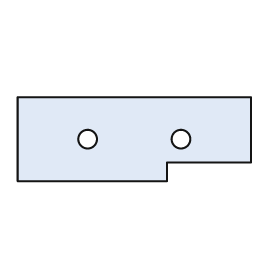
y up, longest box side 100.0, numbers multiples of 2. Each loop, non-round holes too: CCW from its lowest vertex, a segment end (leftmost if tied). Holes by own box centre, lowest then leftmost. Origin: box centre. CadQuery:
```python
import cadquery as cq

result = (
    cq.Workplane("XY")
    .moveTo(-50.0, -18.0)
    .lineTo(14.0, -18.0)
    .lineTo(14.0, -10.0)
    .lineTo(50.0, -10.0)
    .lineTo(50.0, 18.0)
    .lineTo(-50.0, 18.0)
    .close()
    .moveTo(-20.0, 0.0)
    .circle(4.0)
    .moveTo(20.0, 0.0)
    .circle(4.0)
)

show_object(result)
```